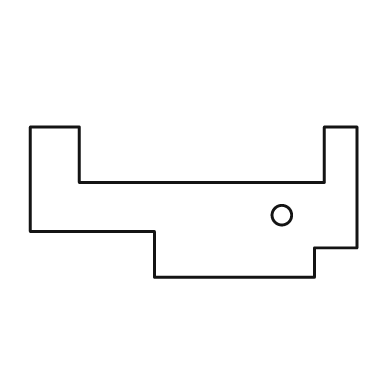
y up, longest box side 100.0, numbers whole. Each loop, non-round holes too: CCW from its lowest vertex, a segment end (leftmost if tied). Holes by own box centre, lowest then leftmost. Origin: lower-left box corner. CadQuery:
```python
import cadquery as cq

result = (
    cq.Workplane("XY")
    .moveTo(38.0, 0.0)
    .lineTo(87.0, 0.0)
    .lineTo(87.0, 9.0)
    .lineTo(100.0, 9.0)
    .lineTo(100.0, 46.0)
    .lineTo(90.0, 46.0)
    .lineTo(90.0, 29.0)
    .lineTo(15.0, 29.0)
    .lineTo(15.0, 46.0)
    .lineTo(0.0, 46.0)
    .lineTo(0.0, 14.0)
    .lineTo(38.0, 14.0)
    .close()
    .moveTo(77.0, 19.0)
    .circle(3.0)
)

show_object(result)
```